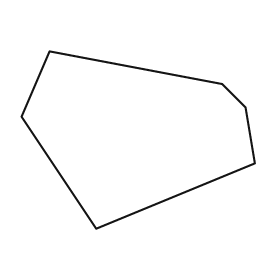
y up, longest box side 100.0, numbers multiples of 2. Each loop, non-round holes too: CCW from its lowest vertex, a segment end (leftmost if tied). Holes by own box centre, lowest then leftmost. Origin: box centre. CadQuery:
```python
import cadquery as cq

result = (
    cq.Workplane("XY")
    .moveTo(-18.0, -38.0)
    .lineTo(50.0, -10.0)
    .lineTo(46.0, 14.0)
    .lineTo(36.0, 24.0)
    .lineTo(-38.0, 38.0)
    .lineTo(-50.0, 10.0)
    .close()
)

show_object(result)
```